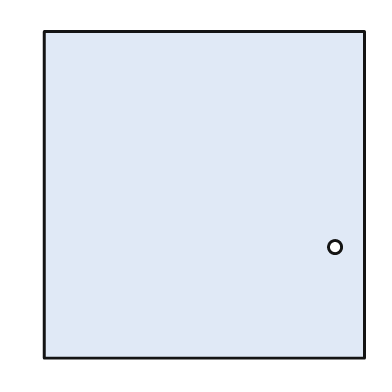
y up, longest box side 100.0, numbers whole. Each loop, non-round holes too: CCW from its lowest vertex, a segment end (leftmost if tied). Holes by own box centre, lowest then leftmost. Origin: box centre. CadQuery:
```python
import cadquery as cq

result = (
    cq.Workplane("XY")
    .moveTo(-49.0, -50.0)
    .lineTo(49.0, -50.0)
    .lineTo(49.0, 50.0)
    .lineTo(-49.0, 50.0)
    .close()
    .moveTo(40.0, -16.0)
    .circle(2.0)
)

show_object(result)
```